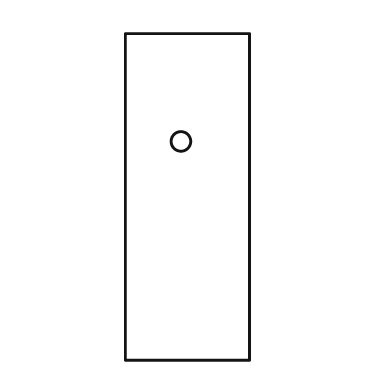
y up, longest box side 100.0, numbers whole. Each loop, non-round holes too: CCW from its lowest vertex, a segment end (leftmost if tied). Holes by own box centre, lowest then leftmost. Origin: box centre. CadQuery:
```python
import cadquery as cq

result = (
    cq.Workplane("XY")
    .moveTo(-19.0, -50.0)
    .lineTo(19.0, -50.0)
    .lineTo(19.0, 50.0)
    .lineTo(-19.0, 50.0)
    .close()
    .moveTo(-2.0, 17.0)
    .circle(3.0)
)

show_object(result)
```